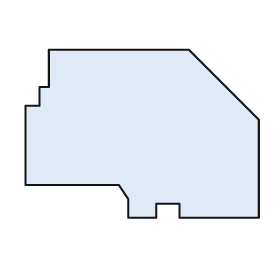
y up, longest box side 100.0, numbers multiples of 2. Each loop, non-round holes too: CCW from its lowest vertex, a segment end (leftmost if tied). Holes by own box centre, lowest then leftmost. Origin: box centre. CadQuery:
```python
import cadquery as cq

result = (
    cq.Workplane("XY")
    .moveTo(-6.0, -36.0)
    .lineTo(6.0, -36.0)
    .lineTo(6.0, -30.0)
    .lineTo(16.0, -30.0)
    .lineTo(16.0, -36.0)
    .lineTo(50.0, -36.0)
    .lineTo(50.0, 6.0)
    .lineTo(20.0, 36.0)
    .lineTo(-40.0, 36.0)
    .lineTo(-40.0, 20.0)
    .lineTo(-44.0, 20.0)
    .lineTo(-44.0, 12.0)
    .lineTo(-50.0, 12.0)
    .lineTo(-50.0, -22.0)
    .lineTo(-10.0, -22.0)
    .lineTo(-6.0, -28.0)
    .close()
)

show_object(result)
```